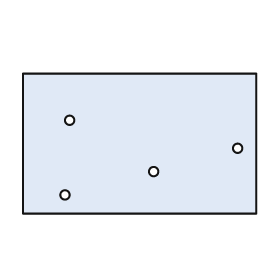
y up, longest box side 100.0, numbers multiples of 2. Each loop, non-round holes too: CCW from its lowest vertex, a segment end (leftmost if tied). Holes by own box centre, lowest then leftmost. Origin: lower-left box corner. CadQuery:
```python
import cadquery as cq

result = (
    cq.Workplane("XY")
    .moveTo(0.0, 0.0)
    .lineTo(100.0, 0.0)
    .lineTo(100.0, 60.0)
    .lineTo(0.0, 60.0)
    .close()
    .moveTo(18.0, 8.0)
    .circle(2.0)
    .moveTo(56.0, 18.0)
    .circle(2.0)
    .moveTo(92.0, 28.0)
    .circle(2.0)
    .moveTo(20.0, 40.0)
    .circle(2.0)
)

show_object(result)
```